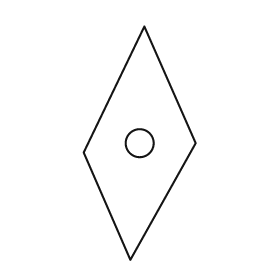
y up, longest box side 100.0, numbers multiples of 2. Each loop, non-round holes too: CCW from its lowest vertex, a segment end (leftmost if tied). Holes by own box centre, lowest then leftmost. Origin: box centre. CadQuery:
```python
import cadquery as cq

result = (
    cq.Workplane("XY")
    .moveTo(-4.0, -50.0)
    .lineTo(24.0, 0.0)
    .lineTo(2.0, 50.0)
    .lineTo(-24.0, -4.0)
    .close()
    .moveTo(0.0, 0.0)
    .circle(6.0)
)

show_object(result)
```